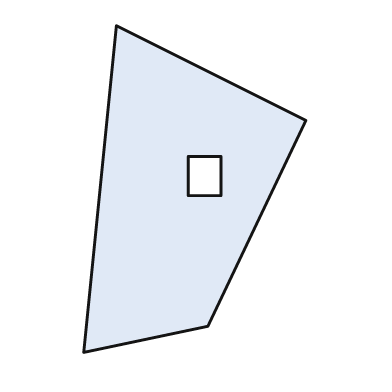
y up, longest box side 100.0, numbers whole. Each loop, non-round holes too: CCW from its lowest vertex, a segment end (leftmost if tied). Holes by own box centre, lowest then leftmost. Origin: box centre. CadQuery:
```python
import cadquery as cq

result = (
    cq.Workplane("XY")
    .moveTo(-34.0, -50.0)
    .lineTo(4.0, -42.0)
    .lineTo(34.0, 21.0)
    .lineTo(-24.0, 50.0)
    .close()
    .moveTo(-2.0, -2.0)
    .lineTo(8.0, -2.0)
    .lineTo(8.0, 10.0)
    .lineTo(-2.0, 10.0)
    .close()
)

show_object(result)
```